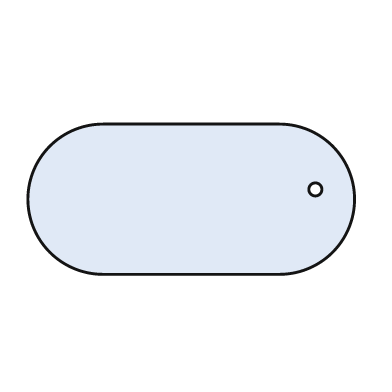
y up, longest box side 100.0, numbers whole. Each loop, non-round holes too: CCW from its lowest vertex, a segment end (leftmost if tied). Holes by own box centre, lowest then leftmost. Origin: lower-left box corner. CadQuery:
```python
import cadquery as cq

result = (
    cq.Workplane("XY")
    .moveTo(23.0, 0.0)
    .lineTo(77.0, 0.0)
    .threePointArc((100.0, 23.0), (77.0, 46.0))
    .lineTo(23.0, 46.0)
    .threePointArc((0.0, 23.0), (23.0, 0.0))
    .close()
    .moveTo(88.0, 26.0)
    .circle(2.0)
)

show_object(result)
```